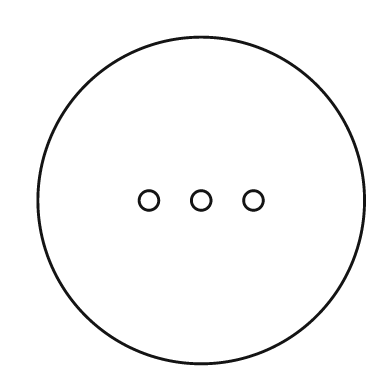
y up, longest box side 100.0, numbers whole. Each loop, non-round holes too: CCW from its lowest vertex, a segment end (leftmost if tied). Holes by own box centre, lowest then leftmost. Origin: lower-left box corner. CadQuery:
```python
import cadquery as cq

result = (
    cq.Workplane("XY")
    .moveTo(50.0, 50.0)
    .circle(50.0)
    .moveTo(34.0, 50.0)
    .circle(3.0)
    .moveTo(50.0, 50.0)
    .circle(3.0)
    .moveTo(66.0, 50.0)
    .circle(3.0)
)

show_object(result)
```